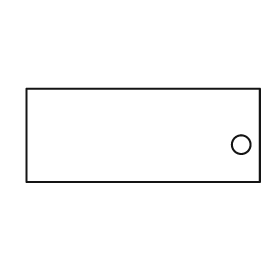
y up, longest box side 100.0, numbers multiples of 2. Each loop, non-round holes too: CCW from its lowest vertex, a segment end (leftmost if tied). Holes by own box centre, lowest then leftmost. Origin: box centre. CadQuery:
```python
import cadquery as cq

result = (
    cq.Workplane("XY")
    .moveTo(-50.0, -20.0)
    .lineTo(50.0, -20.0)
    .lineTo(50.0, 20.0)
    .lineTo(-50.0, 20.0)
    .close()
    .moveTo(42.0, -4.0)
    .circle(4.0)
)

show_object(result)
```